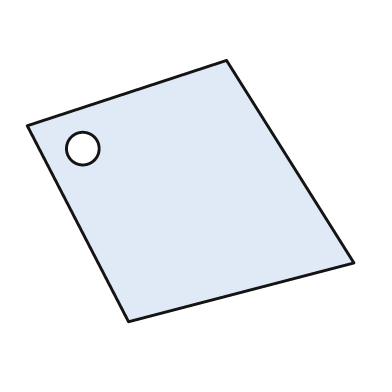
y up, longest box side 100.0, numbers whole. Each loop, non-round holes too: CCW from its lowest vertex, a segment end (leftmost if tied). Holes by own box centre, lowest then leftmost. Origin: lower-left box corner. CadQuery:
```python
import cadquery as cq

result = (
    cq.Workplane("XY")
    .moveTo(31.0, 0.0)
    .lineTo(100.0, 18.0)
    .lineTo(61.0, 80.0)
    .lineTo(0.0, 60.0)
    .close()
    .moveTo(17.0, 53.0)
    .circle(5.0)
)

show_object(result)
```